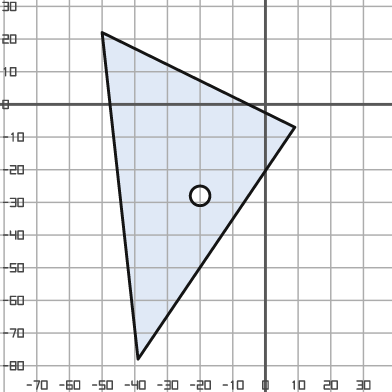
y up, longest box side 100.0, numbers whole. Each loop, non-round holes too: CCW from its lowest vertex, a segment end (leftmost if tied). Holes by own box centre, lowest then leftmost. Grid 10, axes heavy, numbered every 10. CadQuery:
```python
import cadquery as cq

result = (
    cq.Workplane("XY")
    .moveTo(-39.0, -78.0)
    .lineTo(9.0, -7.0)
    .lineTo(-50.0, 22.0)
    .close()
    .moveTo(-20.0, -28.0)
    .circle(3.0)
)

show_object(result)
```